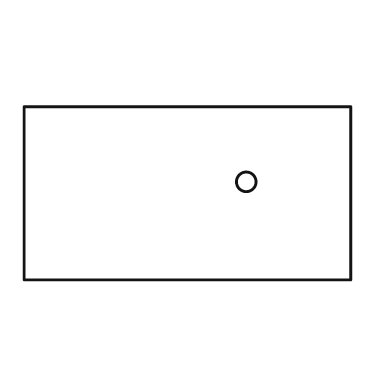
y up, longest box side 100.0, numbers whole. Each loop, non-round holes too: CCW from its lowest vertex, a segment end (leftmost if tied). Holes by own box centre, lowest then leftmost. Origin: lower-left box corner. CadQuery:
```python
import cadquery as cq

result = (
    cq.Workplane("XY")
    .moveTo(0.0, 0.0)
    .lineTo(100.0, 0.0)
    .lineTo(100.0, 53.0)
    .lineTo(0.0, 53.0)
    .close()
    .moveTo(68.0, 30.0)
    .circle(3.0)
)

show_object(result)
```